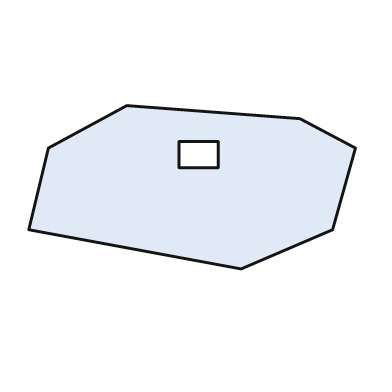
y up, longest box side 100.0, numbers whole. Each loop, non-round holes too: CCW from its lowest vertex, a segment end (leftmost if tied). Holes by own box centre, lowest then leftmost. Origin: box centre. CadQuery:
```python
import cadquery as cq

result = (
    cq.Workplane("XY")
    .moveTo(15.0, -25.0)
    .lineTo(43.0, -13.0)
    .lineTo(50.0, 12.0)
    .lineTo(33.0, 21.0)
    .lineTo(-20.0, 25.0)
    .lineTo(-44.0, 12.0)
    .lineTo(-50.0, -13.0)
    .close()
    .moveTo(-4.0, 6.0)
    .lineTo(8.0, 6.0)
    .lineTo(8.0, 14.0)
    .lineTo(-4.0, 14.0)
    .close()
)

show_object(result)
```